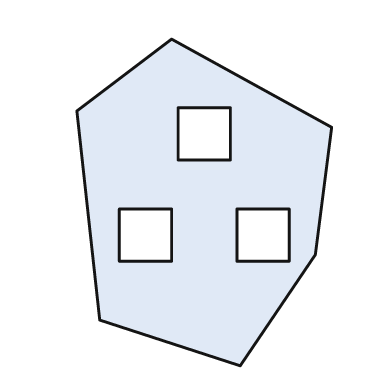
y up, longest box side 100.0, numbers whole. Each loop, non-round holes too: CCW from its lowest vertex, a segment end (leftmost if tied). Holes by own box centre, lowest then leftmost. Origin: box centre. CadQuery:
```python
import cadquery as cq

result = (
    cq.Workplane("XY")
    .moveTo(11.0, -50.0)
    .lineTo(34.0, -16.0)
    .lineTo(39.0, 23.0)
    .lineTo(-10.0, 50.0)
    .lineTo(-39.0, 28.0)
    .lineTo(-32.0, -36.0)
    .close()
    .moveTo(-26.0, -18.0)
    .lineTo(-10.0, -18.0)
    .lineTo(-10.0, -2.0)
    .lineTo(-26.0, -2.0)
    .close()
    .moveTo(10.0, -18.0)
    .lineTo(26.0, -18.0)
    .lineTo(26.0, -2.0)
    .lineTo(10.0, -2.0)
    .close()
    .moveTo(-8.0, 13.0)
    .lineTo(8.0, 13.0)
    .lineTo(8.0, 29.0)
    .lineTo(-8.0, 29.0)
    .close()
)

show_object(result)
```